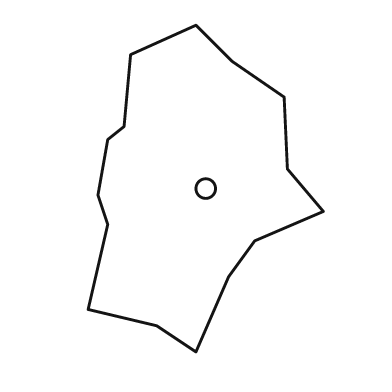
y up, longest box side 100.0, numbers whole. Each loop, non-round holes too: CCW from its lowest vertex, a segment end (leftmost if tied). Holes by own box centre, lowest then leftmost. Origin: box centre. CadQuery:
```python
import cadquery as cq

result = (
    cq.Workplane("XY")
    .moveTo(-3.0, -50.0)
    .lineTo(7.0, -27.0)
    .lineTo(15.0, -16.0)
    .lineTo(36.0, -7.0)
    .lineTo(25.0, 6.0)
    .lineTo(24.0, 28.0)
    .lineTo(8.0, 39.0)
    .lineTo(-3.0, 50.0)
    .lineTo(-23.0, 41.0)
    .lineTo(-25.0, 19.0)
    .lineTo(-30.0, 15.0)
    .lineTo(-33.0, -2.0)
    .lineTo(-30.0, -11.0)
    .lineTo(-36.0, -37.0)
    .lineTo(-15.0, -42.0)
    .close()
    .moveTo(0.0, 0.0)
    .circle(3.0)
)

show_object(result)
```